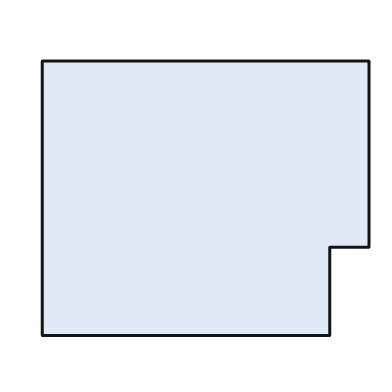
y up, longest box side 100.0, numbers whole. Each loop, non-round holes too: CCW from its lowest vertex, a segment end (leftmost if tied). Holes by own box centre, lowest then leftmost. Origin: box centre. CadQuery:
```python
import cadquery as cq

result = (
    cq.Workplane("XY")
    .moveTo(-50.0, -42.0)
    .lineTo(38.0, -42.0)
    .lineTo(38.0, -15.0)
    .lineTo(50.0, -15.0)
    .lineTo(50.0, 42.0)
    .lineTo(-50.0, 42.0)
    .close()
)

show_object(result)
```